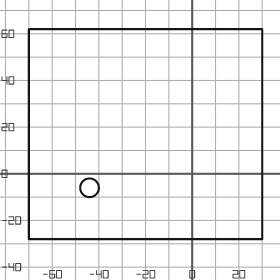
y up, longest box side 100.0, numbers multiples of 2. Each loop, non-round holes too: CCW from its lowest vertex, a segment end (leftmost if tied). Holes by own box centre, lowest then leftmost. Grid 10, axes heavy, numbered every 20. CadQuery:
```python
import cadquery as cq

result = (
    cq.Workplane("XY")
    .moveTo(-70.0, -28.0)
    .lineTo(30.0, -28.0)
    .lineTo(30.0, 62.0)
    .lineTo(-70.0, 62.0)
    .close()
    .moveTo(-44.0, -6.0)
    .circle(4.0)
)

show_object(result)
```